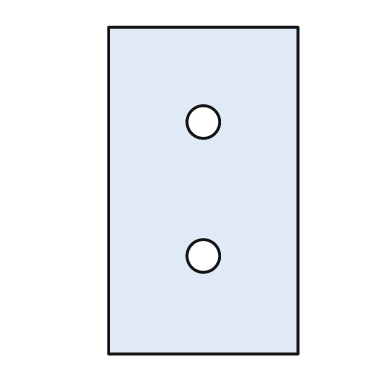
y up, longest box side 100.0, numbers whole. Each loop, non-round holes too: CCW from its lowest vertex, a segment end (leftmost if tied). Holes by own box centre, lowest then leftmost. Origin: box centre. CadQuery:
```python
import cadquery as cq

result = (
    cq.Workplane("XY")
    .moveTo(-29.0, -50.0)
    .lineTo(29.0, -50.0)
    .lineTo(29.0, 50.0)
    .lineTo(-29.0, 50.0)
    .close()
    .moveTo(0.0, -20.0)
    .circle(5.0)
    .moveTo(0.0, 21.0)
    .circle(5.0)
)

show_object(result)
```